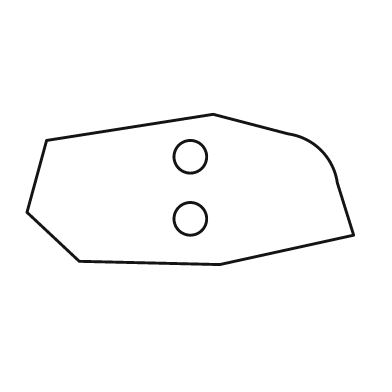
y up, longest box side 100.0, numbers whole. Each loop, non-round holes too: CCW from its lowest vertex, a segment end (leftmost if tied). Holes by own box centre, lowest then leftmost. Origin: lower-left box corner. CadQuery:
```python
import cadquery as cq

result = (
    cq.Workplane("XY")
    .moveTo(59.0, 0.0)
    .lineTo(100.0, 9.0)
    .lineTo(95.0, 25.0)
    .threePointArc((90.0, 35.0), (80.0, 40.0))
    .lineTo(57.0, 46.0)
    .lineTo(6.0, 38.0)
    .lineTo(0.0, 16.0)
    .lineTo(16.0, 1.0)
    .close()
    .moveTo(50.0, 14.0)
    .circle(5.0)
    .moveTo(50.0, 33.0)
    .circle(5.0)
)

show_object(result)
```